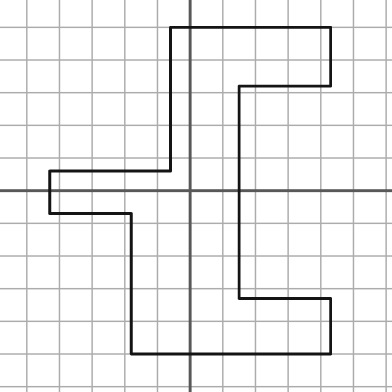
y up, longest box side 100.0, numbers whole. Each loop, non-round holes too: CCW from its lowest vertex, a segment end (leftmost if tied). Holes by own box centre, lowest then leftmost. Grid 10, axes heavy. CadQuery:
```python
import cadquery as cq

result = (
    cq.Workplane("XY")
    .moveTo(-18.0, -50.0)
    .lineTo(43.0, -50.0)
    .lineTo(43.0, -33.0)
    .lineTo(15.0, -33.0)
    .lineTo(15.0, 32.0)
    .lineTo(43.0, 32.0)
    .lineTo(43.0, 50.0)
    .lineTo(-6.0, 50.0)
    .lineTo(-6.0, 6.0)
    .lineTo(-43.0, 6.0)
    .lineTo(-43.0, -7.0)
    .lineTo(-18.0, -7.0)
    .close()
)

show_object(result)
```